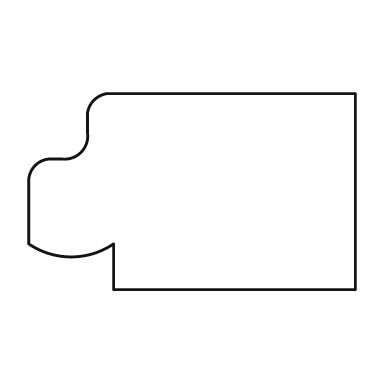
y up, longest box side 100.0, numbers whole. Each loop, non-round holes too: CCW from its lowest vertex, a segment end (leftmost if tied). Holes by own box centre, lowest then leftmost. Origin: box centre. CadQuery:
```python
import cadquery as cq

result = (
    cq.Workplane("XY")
    .moveTo(-24.0, -30.0)
    .lineTo(50.0, -30.0)
    .lineTo(50.0, 30.0)
    .lineTo(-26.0, 30.0)
    .threePointArc((-30.0, 28.0), (-32.0, 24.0))
    .lineTo(-32.0, 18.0)
    .threePointArc((-34.0, 12.0), (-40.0, 10.0))
    .lineTo(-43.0, 10.0)
    .threePointArc((-48.0, 8.0), (-50.0, 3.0))
    .lineTo(-50.0, -16.0)
    .threePointArc((-37.0, -20.0), (-24.0, -16.0))
    .close()
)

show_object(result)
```